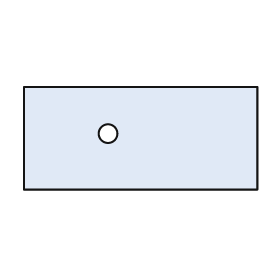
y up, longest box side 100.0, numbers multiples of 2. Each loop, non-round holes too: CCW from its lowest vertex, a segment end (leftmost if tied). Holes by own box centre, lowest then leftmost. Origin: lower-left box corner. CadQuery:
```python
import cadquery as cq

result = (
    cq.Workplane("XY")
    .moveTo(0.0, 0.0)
    .lineTo(100.0, 0.0)
    .lineTo(100.0, 44.0)
    .lineTo(0.0, 44.0)
    .close()
    .moveTo(36.0, 24.0)
    .circle(4.0)
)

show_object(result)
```